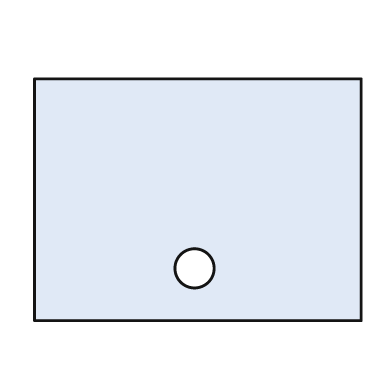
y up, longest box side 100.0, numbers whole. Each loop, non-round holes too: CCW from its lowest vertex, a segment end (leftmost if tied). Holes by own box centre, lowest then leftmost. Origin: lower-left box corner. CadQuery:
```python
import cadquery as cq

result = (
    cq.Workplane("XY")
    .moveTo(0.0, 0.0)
    .lineTo(100.0, 0.0)
    .lineTo(100.0, 74.0)
    .lineTo(0.0, 74.0)
    .close()
    .moveTo(49.0, 16.0)
    .circle(6.0)
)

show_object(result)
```